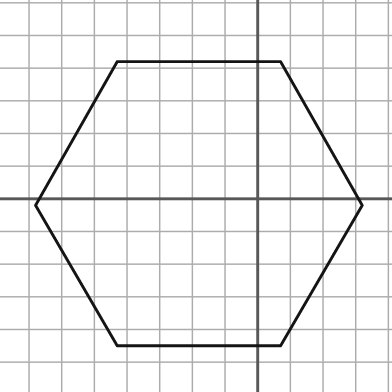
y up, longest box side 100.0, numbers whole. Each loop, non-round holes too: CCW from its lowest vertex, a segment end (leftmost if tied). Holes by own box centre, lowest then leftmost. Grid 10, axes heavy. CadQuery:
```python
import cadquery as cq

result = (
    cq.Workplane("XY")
    .moveTo(-43.0, -45.0)
    .lineTo(7.0, -45.0)
    .lineTo(32.0, -2.0)
    .lineTo(7.0, 42.0)
    .lineTo(-43.0, 42.0)
    .lineTo(-68.0, -2.0)
    .close()
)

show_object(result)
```